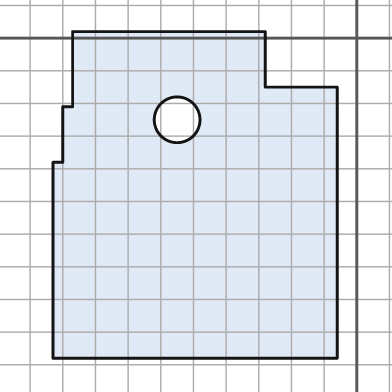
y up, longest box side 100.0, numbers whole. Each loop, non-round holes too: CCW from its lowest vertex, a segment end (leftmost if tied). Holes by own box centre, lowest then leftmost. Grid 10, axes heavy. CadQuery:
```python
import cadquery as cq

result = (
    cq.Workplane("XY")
    .moveTo(-93.0, -98.0)
    .lineTo(-6.0, -98.0)
    .lineTo(-6.0, -15.0)
    .lineTo(-28.0, -15.0)
    .lineTo(-28.0, 2.0)
    .lineTo(-87.0, 2.0)
    .lineTo(-87.0, -21.0)
    .lineTo(-90.0, -21.0)
    .lineTo(-90.0, -38.0)
    .lineTo(-93.0, -38.0)
    .close()
    .moveTo(-55.0, -25.0)
    .circle(7.0)
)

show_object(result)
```